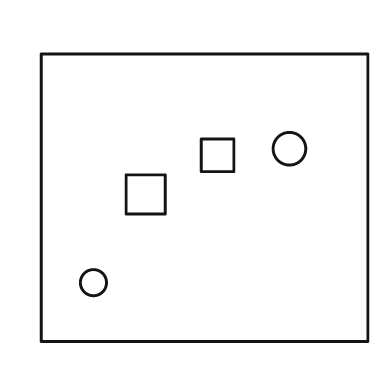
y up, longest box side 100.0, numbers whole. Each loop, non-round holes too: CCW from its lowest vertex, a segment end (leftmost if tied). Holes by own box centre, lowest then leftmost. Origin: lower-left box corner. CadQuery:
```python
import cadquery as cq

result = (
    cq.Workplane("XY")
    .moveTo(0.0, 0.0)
    .lineTo(100.0, 0.0)
    .lineTo(100.0, 88.0)
    .lineTo(0.0, 88.0)
    .close()
    .moveTo(16.0, 18.0)
    .circle(4.0)
    .moveTo(26.0, 39.0)
    .lineTo(38.0, 39.0)
    .lineTo(38.0, 51.0)
    .lineTo(26.0, 51.0)
    .close()
    .moveTo(49.0, 52.0)
    .lineTo(59.0, 52.0)
    .lineTo(59.0, 62.0)
    .lineTo(49.0, 62.0)
    .close()
    .moveTo(76.0, 59.0)
    .circle(5.0)
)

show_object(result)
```